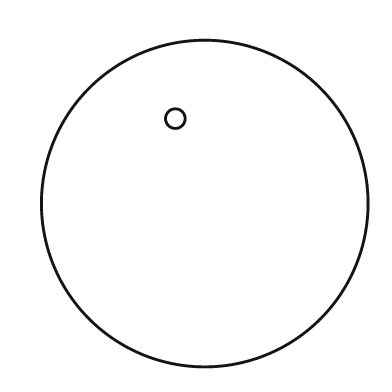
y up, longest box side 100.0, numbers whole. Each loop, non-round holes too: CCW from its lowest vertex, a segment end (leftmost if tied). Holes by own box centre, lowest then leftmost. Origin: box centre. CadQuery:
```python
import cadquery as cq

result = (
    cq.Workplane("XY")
    .moveTo(0.0, 0.0)
    .circle(50.0)
    .moveTo(-9.0, 26.0)
    .circle(3.0)
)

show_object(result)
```